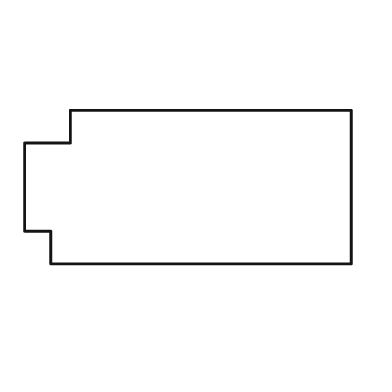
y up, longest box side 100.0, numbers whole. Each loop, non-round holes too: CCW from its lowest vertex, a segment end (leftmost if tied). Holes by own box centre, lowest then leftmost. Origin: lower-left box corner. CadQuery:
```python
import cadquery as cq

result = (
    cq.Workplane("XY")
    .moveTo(8.0, 0.0)
    .lineTo(100.0, 0.0)
    .lineTo(100.0, 47.0)
    .lineTo(14.0, 47.0)
    .lineTo(14.0, 37.0)
    .lineTo(0.0, 37.0)
    .lineTo(0.0, 10.0)
    .lineTo(8.0, 10.0)
    .close()
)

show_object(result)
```